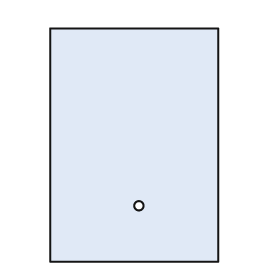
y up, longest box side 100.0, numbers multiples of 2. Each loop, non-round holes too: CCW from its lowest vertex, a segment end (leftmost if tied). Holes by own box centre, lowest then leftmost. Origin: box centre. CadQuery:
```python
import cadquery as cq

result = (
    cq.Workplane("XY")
    .moveTo(-36.0, -50.0)
    .lineTo(36.0, -50.0)
    .lineTo(36.0, 50.0)
    .lineTo(-36.0, 50.0)
    .close()
    .moveTo(2.0, -26.0)
    .circle(2.0)
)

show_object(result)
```